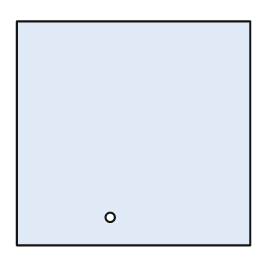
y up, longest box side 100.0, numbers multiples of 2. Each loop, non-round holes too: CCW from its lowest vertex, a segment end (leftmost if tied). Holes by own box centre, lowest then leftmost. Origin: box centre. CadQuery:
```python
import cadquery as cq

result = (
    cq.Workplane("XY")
    .moveTo(-50.0, -48.0)
    .lineTo(50.0, -48.0)
    .lineTo(50.0, 48.0)
    .lineTo(-50.0, 48.0)
    .close()
    .moveTo(-10.0, -36.0)
    .circle(2.0)
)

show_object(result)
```